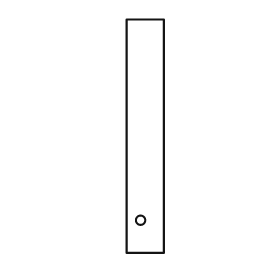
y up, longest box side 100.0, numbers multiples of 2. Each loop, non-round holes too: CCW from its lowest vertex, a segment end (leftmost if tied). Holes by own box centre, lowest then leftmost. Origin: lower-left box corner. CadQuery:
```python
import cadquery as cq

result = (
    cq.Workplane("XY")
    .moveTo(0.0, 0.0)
    .lineTo(16.0, 0.0)
    .lineTo(16.0, 100.0)
    .lineTo(0.0, 100.0)
    .close()
    .moveTo(6.0, 14.0)
    .circle(2.0)
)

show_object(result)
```